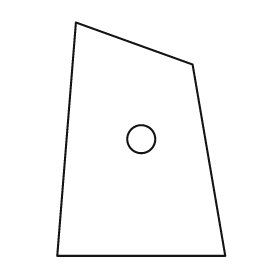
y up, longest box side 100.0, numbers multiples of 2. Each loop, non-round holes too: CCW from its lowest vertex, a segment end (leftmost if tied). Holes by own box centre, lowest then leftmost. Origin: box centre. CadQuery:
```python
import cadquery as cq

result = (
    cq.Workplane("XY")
    .moveTo(-36.0, -50.0)
    .lineTo(36.0, -50.0)
    .lineTo(22.0, 32.0)
    .lineTo(-28.0, 50.0)
    .close()
    .moveTo(0.0, 0.0)
    .circle(6.0)
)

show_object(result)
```